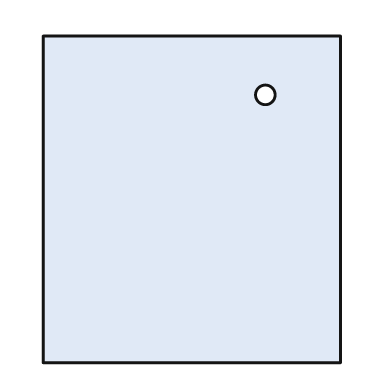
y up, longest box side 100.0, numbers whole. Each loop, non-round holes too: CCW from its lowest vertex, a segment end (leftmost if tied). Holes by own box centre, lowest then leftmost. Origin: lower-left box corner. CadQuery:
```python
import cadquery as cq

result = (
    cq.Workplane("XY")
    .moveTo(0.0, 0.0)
    .lineTo(91.0, 0.0)
    .lineTo(91.0, 100.0)
    .lineTo(0.0, 100.0)
    .close()
    .moveTo(68.0, 82.0)
    .circle(3.0)
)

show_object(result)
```